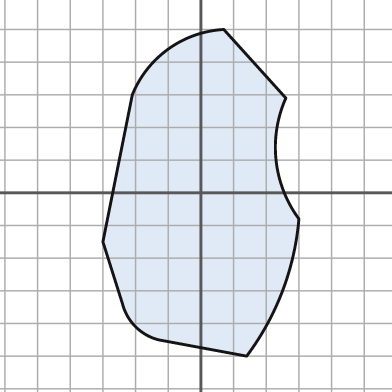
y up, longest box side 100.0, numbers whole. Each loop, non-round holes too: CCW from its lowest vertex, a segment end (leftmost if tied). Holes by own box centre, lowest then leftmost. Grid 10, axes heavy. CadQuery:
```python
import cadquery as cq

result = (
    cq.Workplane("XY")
    .moveTo(14.0, -50.0)
    .threePointArc((25.0, -30.0), (30.0, -8.0))
    .threePointArc((23.0, 10.0), (26.0, 29.0))
    .lineTo(7.0, 50.0)
    .threePointArc((-10.0, 44.0), (-21.0, 30.0))
    .lineTo(-30.0, -15.0)
    .lineTo(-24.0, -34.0)
    .threePointArc((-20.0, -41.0), (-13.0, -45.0))
    .close()
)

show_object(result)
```